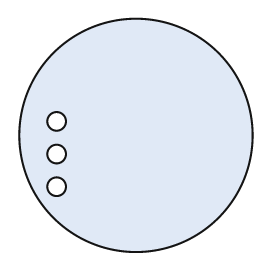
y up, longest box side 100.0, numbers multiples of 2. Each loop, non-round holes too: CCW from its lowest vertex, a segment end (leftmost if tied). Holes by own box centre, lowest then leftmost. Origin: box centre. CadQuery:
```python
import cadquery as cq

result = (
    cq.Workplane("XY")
    .moveTo(0.0, 0.0)
    .circle(50.0)
    .moveTo(-34.0, -22.0)
    .circle(4.0)
    .moveTo(-34.0, -8.0)
    .circle(4.0)
    .moveTo(-34.0, 6.0)
    .circle(4.0)
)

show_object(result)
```